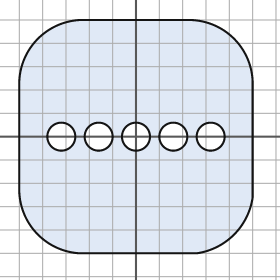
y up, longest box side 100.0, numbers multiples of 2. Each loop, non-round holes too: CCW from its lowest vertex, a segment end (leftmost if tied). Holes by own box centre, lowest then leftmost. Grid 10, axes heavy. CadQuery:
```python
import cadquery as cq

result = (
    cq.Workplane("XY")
    .moveTo(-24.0, -50.0)
    .lineTo(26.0, -50.0)
    .threePointArc((42.0, -42.0), (50.0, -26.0))
    .lineTo(50.0, 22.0)
    .threePointArc((42.0, 42.0), (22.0, 50.0))
    .lineTo(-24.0, 50.0)
    .threePointArc((-42.0, 42.0), (-50.0, 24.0))
    .lineTo(-50.0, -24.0)
    .threePointArc((-42.0, -42.0), (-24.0, -50.0))
    .close()
    .moveTo(-32.0, 0.0)
    .circle(6.0)
    .moveTo(-16.0, 0.0)
    .circle(6.0)
    .moveTo(0.0, 0.0)
    .circle(6.0)
    .moveTo(16.0, 0.0)
    .circle(6.0)
    .moveTo(32.0, 0.0)
    .circle(6.0)
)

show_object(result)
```